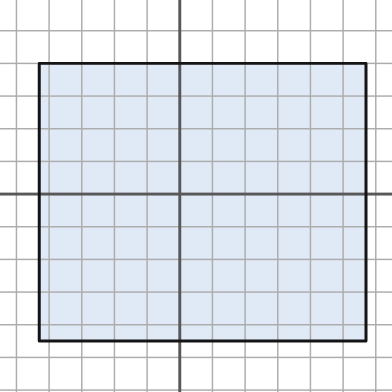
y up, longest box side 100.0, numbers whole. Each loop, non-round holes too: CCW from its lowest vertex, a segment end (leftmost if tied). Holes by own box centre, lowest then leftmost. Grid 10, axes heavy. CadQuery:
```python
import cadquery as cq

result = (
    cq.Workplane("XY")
    .moveTo(-43.0, -45.0)
    .lineTo(57.0, -45.0)
    .lineTo(57.0, 40.0)
    .lineTo(-43.0, 40.0)
    .close()
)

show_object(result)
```